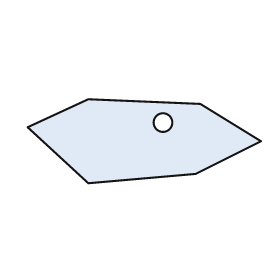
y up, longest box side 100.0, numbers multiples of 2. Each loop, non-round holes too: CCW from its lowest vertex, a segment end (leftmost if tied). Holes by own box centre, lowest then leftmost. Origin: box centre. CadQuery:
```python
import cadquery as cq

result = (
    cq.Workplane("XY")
    .moveTo(-24.0, -18.0)
    .lineTo(22.0, -14.0)
    .lineTo(50.0, 0.0)
    .lineTo(24.0, 16.0)
    .lineTo(-24.0, 18.0)
    .lineTo(-50.0, 6.0)
    .close()
    .moveTo(8.0, 8.0)
    .circle(4.0)
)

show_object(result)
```